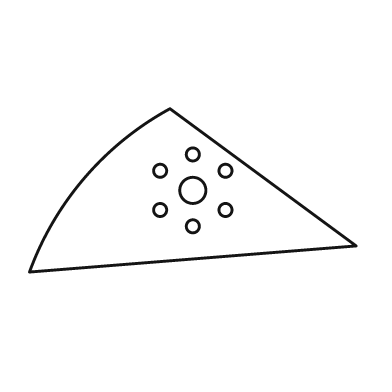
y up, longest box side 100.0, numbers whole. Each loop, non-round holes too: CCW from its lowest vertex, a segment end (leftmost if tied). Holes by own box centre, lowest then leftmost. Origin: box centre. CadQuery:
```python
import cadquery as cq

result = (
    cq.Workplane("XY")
    .moveTo(-50.0, -25.0)
    .lineTo(50.0, -17.0)
    .lineTo(-7.0, 25.0)
    .threePointArc((-33.0, 4.0), (-50.0, -25.0))
    .close()
    .moveTo(0.0, -11.0)
    .circle(2.0)
    .moveTo(-10.0, -6.0)
    .circle(2.0)
    .moveTo(10.0, -6.0)
    .circle(2.0)
    .moveTo(0.0, 0.0)
    .circle(4.0)
    .moveTo(-10.0, 6.0)
    .circle(2.0)
    .moveTo(10.0, 6.0)
    .circle(2.0)
    .moveTo(0.0, 11.0)
    .circle(2.0)
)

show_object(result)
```